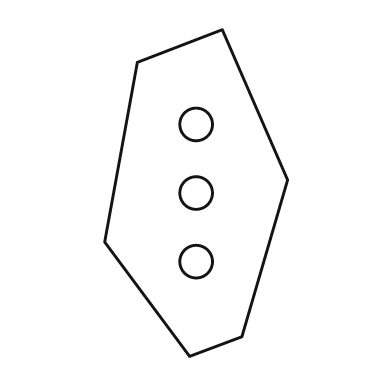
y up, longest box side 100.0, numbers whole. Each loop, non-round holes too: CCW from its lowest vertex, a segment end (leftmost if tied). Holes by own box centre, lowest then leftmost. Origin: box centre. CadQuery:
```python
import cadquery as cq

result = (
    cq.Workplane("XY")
    .moveTo(-2.0, -50.0)
    .lineTo(14.0, -44.0)
    .lineTo(28.0, 4.0)
    .lineTo(8.0, 50.0)
    .lineTo(-18.0, 40.0)
    .lineTo(-28.0, -15.0)
    .close()
    .moveTo(0.0, -21.0)
    .circle(5.0)
    .moveTo(0.0, 0.0)
    .circle(5.0)
    .moveTo(0.0, 21.0)
    .circle(5.0)
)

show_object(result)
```